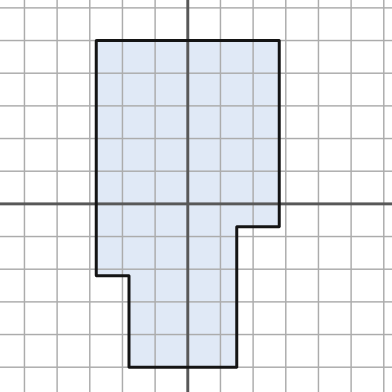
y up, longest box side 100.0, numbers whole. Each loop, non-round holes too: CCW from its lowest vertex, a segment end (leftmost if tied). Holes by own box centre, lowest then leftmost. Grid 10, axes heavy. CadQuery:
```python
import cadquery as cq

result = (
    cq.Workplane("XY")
    .moveTo(-18.0, -50.0)
    .lineTo(15.0, -50.0)
    .lineTo(15.0, -7.0)
    .lineTo(28.0, -7.0)
    .lineTo(28.0, 50.0)
    .lineTo(-28.0, 50.0)
    .lineTo(-28.0, -22.0)
    .lineTo(-18.0, -22.0)
    .close()
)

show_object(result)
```